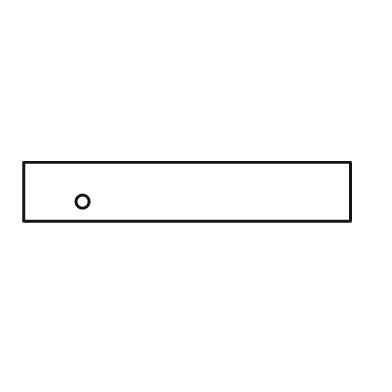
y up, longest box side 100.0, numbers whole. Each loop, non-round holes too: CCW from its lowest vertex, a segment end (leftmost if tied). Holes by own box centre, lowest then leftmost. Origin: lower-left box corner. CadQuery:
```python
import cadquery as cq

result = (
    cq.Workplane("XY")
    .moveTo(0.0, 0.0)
    .lineTo(100.0, 0.0)
    .lineTo(100.0, 18.0)
    .lineTo(0.0, 18.0)
    .close()
    .moveTo(18.0, 6.0)
    .circle(2.0)
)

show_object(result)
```